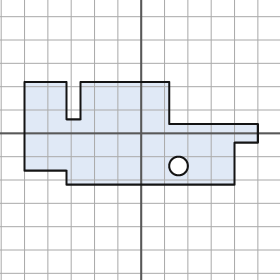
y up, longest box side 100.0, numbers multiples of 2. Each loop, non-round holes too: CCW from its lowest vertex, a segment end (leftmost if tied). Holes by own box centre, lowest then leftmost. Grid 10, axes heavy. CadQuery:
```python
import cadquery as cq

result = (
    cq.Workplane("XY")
    .moveTo(-32.0, -22.0)
    .lineTo(40.0, -22.0)
    .lineTo(40.0, -4.0)
    .lineTo(50.0, -4.0)
    .lineTo(50.0, 4.0)
    .lineTo(12.0, 4.0)
    .lineTo(12.0, 22.0)
    .lineTo(-26.0, 22.0)
    .lineTo(-26.0, 6.0)
    .lineTo(-32.0, 6.0)
    .lineTo(-32.0, 22.0)
    .lineTo(-50.0, 22.0)
    .lineTo(-50.0, -16.0)
    .lineTo(-32.0, -16.0)
    .close()
    .moveTo(16.0, -14.0)
    .circle(4.0)
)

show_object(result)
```